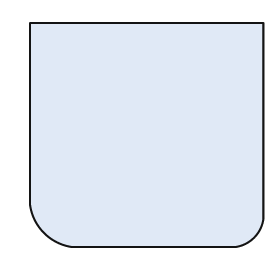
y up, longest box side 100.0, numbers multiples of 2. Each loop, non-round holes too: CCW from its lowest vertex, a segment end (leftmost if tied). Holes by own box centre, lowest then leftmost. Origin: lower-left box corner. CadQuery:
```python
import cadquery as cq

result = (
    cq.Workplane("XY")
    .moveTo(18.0, 0.0)
    .lineTo(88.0, 0.0)
    .threePointArc((96.0, 4.0), (100.0, 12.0))
    .lineTo(100.0, 96.0)
    .lineTo(0.0, 96.0)
    .lineTo(0.0, 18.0)
    .threePointArc((6.0, 6.0), (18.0, 0.0))
    .close()
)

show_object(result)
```